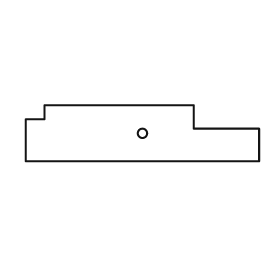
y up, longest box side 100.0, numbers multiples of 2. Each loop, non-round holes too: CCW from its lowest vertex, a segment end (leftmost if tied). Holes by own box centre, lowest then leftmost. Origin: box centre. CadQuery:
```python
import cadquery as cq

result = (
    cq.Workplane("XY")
    .moveTo(-50.0, -12.0)
    .lineTo(50.0, -12.0)
    .lineTo(50.0, 2.0)
    .lineTo(22.0, 2.0)
    .lineTo(22.0, 12.0)
    .lineTo(-42.0, 12.0)
    .lineTo(-42.0, 6.0)
    .lineTo(-50.0, 6.0)
    .close()
    .moveTo(0.0, 0.0)
    .circle(2.0)
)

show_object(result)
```